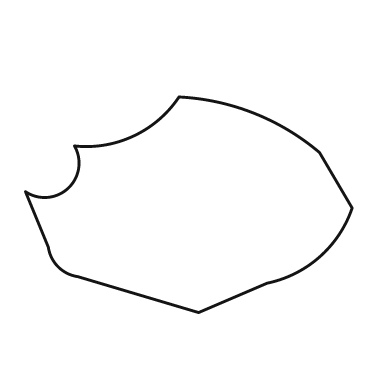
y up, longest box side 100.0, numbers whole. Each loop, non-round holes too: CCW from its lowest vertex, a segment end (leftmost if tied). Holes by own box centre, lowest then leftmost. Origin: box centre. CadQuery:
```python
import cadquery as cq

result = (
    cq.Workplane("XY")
    .moveTo(3.0, -33.0)
    .lineTo(24.0, -24.0)
    .threePointArc((40.0, -16.0), (50.0, -1.0))
    .lineTo(40.0, 16.0)
    .threePointArc((20.0, 28.0), (-3.0, 33.0))
    .threePointArc((-17.0, 21.0), (-35.0, 18.0))
    .threePointArc((-37.0, 5.0), (-50.0, 4.0))
    .lineTo(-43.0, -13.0)
    .threePointArc((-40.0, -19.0), (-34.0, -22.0))
    .close()
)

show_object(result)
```